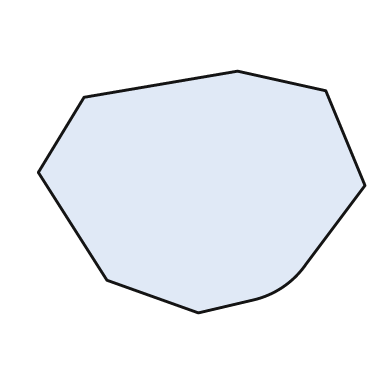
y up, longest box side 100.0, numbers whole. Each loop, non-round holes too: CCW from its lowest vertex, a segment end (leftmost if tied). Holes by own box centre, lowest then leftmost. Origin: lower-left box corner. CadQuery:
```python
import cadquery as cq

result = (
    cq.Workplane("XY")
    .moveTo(49.0, 0.0)
    .lineTo(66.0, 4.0)
    .threePointArc((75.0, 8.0), (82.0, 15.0))
    .lineTo(100.0, 39.0)
    .lineTo(88.0, 68.0)
    .lineTo(61.0, 74.0)
    .lineTo(14.0, 66.0)
    .lineTo(0.0, 43.0)
    .lineTo(21.0, 10.0)
    .close()
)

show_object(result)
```